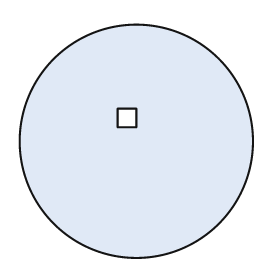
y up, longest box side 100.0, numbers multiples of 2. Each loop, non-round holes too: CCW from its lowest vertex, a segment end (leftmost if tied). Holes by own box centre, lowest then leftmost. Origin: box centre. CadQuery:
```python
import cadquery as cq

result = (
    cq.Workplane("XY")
    .moveTo(0.0, 0.0)
    .circle(50.0)
    .moveTo(-8.0, 6.0)
    .lineTo(0.0, 6.0)
    .lineTo(0.0, 14.0)
    .lineTo(-8.0, 14.0)
    .close()
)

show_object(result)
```